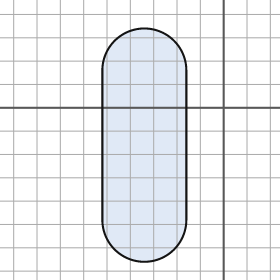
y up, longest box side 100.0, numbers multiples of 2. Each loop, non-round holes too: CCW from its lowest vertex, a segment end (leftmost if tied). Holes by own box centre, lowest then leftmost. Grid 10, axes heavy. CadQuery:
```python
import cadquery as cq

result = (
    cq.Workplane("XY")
    .moveTo(-52.0, -48.0)
    .threePointArc((-34.0, -66.0), (-16.0, -48.0))
    .lineTo(-16.0, 16.0)
    .threePointArc((-34.0, 34.0), (-52.0, 16.0))
    .close()
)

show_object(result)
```